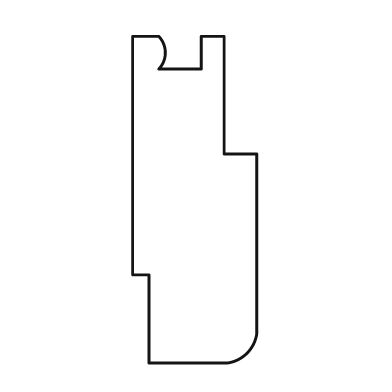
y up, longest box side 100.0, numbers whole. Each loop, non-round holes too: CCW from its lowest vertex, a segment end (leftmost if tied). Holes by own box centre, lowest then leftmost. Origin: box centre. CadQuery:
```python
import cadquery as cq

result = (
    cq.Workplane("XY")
    .moveTo(-14.0, -50.0)
    .lineTo(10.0, -50.0)
    .threePointArc((16.0, -47.0), (19.0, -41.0))
    .lineTo(19.0, 14.0)
    .lineTo(9.0, 14.0)
    .lineTo(9.0, 50.0)
    .lineTo(2.0, 50.0)
    .lineTo(2.0, 40.0)
    .lineTo(-11.0, 40.0)
    .threePointArc((-9.0, 45.0), (-11.0, 50.0))
    .lineTo(-19.0, 50.0)
    .lineTo(-19.0, -23.0)
    .lineTo(-14.0, -23.0)
    .close()
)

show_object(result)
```